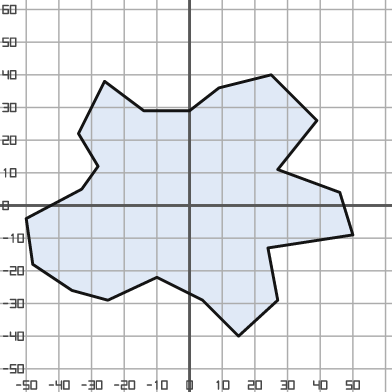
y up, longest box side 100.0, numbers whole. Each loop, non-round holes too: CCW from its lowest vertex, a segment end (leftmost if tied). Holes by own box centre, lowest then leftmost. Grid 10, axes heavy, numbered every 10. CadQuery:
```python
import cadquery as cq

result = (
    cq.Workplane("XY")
    .moveTo(15.0, -40.0)
    .lineTo(27.0, -29.0)
    .lineTo(24.0, -13.0)
    .lineTo(50.0, -9.0)
    .lineTo(46.0, 4.0)
    .lineTo(27.0, 11.0)
    .lineTo(39.0, 26.0)
    .lineTo(25.0, 40.0)
    .lineTo(9.0, 36.0)
    .lineTo(0.0, 29.0)
    .lineTo(-14.0, 29.0)
    .lineTo(-26.0, 38.0)
    .lineTo(-34.0, 22.0)
    .lineTo(-28.0, 12.0)
    .lineTo(-33.0, 5.0)
    .lineTo(-50.0, -4.0)
    .lineTo(-48.0, -18.0)
    .lineTo(-36.0, -26.0)
    .lineTo(-25.0, -29.0)
    .lineTo(-10.0, -22.0)
    .lineTo(4.0, -29.0)
    .close()
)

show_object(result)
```